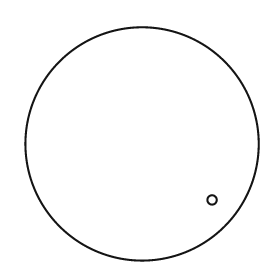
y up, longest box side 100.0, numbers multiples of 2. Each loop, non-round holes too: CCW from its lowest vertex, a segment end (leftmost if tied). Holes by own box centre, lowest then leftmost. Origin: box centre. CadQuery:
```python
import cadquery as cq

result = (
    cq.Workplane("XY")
    .moveTo(0.0, 0.0)
    .circle(50.0)
    .moveTo(30.0, -24.0)
    .circle(2.0)
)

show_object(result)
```